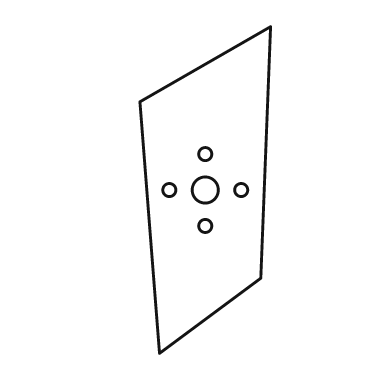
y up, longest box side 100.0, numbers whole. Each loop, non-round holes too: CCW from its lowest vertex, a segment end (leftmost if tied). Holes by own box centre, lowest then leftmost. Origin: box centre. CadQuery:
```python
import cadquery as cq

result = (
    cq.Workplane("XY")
    .moveTo(-14.0, -50.0)
    .lineTo(17.0, -27.0)
    .lineTo(20.0, 50.0)
    .lineTo(-20.0, 27.0)
    .close()
    .moveTo(0.0, -11.0)
    .circle(2.0)
    .moveTo(-11.0, 0.0)
    .circle(2.0)
    .moveTo(0.0, 0.0)
    .circle(4.0)
    .moveTo(11.0, 0.0)
    .circle(2.0)
    .moveTo(0.0, 11.0)
    .circle(2.0)
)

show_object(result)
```